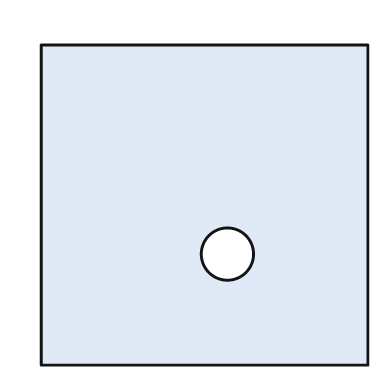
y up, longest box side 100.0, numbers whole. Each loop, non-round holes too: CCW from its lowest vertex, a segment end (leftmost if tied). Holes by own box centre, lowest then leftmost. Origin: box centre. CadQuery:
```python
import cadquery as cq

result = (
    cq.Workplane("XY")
    .moveTo(-50.0, -49.0)
    .lineTo(50.0, -49.0)
    .lineTo(50.0, 49.0)
    .lineTo(-50.0, 49.0)
    .close()
    .moveTo(7.0, -15.0)
    .circle(8.0)
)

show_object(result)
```